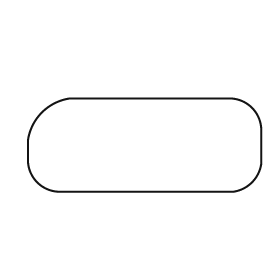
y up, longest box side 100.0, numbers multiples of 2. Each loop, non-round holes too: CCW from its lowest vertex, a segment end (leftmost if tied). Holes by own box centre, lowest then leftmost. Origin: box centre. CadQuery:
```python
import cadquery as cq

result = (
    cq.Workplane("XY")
    .moveTo(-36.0, -20.0)
    .lineTo(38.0, -20.0)
    .threePointArc((46.0, -16.0), (50.0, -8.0))
    .lineTo(50.0, 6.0)
    .threePointArc((46.0, 16.0), (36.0, 20.0))
    .lineTo(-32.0, 20.0)
    .threePointArc((-44.0, 14.0), (-50.0, 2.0))
    .lineTo(-50.0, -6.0)
    .threePointArc((-46.0, -16.0), (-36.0, -20.0))
    .close()
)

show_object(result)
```